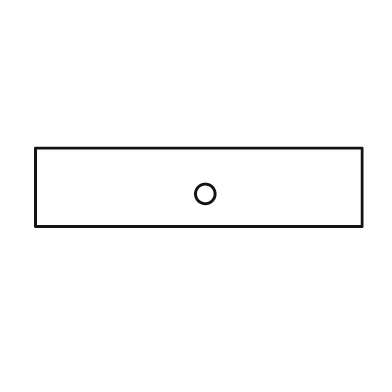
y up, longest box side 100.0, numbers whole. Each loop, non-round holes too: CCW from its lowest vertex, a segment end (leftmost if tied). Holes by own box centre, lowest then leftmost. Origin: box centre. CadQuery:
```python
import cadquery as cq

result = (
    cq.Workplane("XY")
    .moveTo(-50.0, -12.0)
    .lineTo(50.0, -12.0)
    .lineTo(50.0, 12.0)
    .lineTo(-50.0, 12.0)
    .close()
    .moveTo(2.0, -2.0)
    .circle(3.0)
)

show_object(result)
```